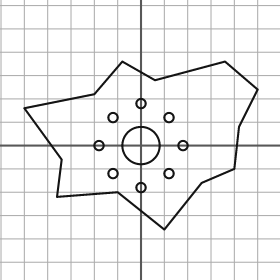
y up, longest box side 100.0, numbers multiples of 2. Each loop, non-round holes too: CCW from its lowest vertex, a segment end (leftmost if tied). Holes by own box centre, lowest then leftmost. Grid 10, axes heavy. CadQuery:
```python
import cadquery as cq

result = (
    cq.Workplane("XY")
    .moveTo(10.0, -36.0)
    .lineTo(26.0, -16.0)
    .lineTo(40.0, -10.0)
    .lineTo(42.0, 8.0)
    .lineTo(50.0, 24.0)
    .lineTo(36.0, 36.0)
    .lineTo(6.0, 28.0)
    .lineTo(-8.0, 36.0)
    .lineTo(-20.0, 22.0)
    .lineTo(-50.0, 16.0)
    .lineTo(-34.0, -6.0)
    .lineTo(-36.0, -22.0)
    .lineTo(-10.0, -20.0)
    .close()
    .moveTo(0.0, -18.0)
    .circle(2.0)
    .moveTo(-12.0, -12.0)
    .circle(2.0)
    .moveTo(12.0, -12.0)
    .circle(2.0)
    .moveTo(-18.0, 0.0)
    .circle(2.0)
    .moveTo(0.0, 0.0)
    .circle(8.0)
    .moveTo(18.0, 0.0)
    .circle(2.0)
    .moveTo(-12.0, 12.0)
    .circle(2.0)
    .moveTo(12.0, 12.0)
    .circle(2.0)
    .moveTo(0.0, 18.0)
    .circle(2.0)
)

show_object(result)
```